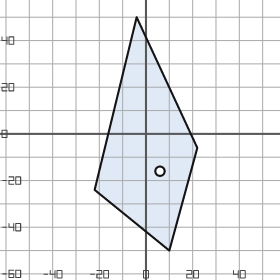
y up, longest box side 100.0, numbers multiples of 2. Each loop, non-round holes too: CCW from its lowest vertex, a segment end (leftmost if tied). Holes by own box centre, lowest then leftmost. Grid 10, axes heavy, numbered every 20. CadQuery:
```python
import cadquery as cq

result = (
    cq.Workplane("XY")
    .moveTo(10.0, -50.0)
    .lineTo(22.0, -6.0)
    .lineTo(-4.0, 50.0)
    .lineTo(-22.0, -24.0)
    .close()
    .moveTo(6.0, -16.0)
    .circle(2.0)
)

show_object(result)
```